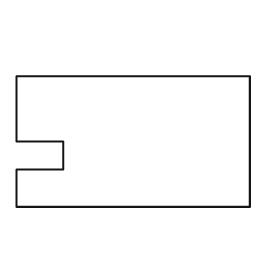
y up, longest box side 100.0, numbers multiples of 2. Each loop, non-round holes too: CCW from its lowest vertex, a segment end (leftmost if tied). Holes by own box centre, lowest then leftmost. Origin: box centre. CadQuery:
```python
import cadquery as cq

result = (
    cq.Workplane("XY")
    .moveTo(-50.0, -28.0)
    .lineTo(50.0, -28.0)
    .lineTo(50.0, 28.0)
    .lineTo(-50.0, 28.0)
    .lineTo(-50.0, 0.0)
    .lineTo(-30.0, 0.0)
    .lineTo(-30.0, -12.0)
    .lineTo(-50.0, -12.0)
    .close()
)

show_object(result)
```